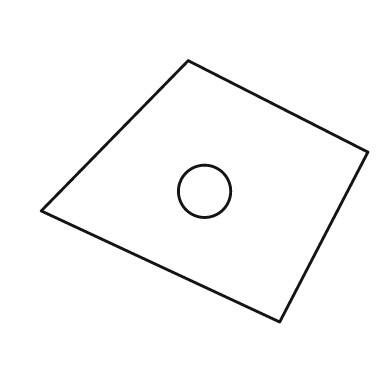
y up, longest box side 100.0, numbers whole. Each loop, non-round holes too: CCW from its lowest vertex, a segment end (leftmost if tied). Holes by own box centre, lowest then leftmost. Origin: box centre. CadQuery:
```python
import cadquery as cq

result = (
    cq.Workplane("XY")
    .moveTo(23.0, -40.0)
    .lineTo(50.0, 12.0)
    .lineTo(-5.0, 40.0)
    .lineTo(-50.0, -6.0)
    .close()
    .moveTo(0.0, 0.0)
    .circle(8.0)
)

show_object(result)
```